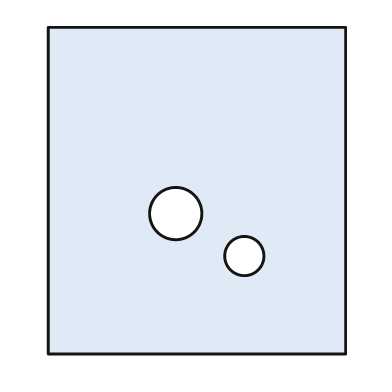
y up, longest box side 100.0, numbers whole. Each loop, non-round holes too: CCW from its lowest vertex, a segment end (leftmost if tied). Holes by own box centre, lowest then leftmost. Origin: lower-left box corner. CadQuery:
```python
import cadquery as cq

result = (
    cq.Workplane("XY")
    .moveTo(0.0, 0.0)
    .lineTo(91.0, 0.0)
    .lineTo(91.0, 100.0)
    .lineTo(0.0, 100.0)
    .close()
    .moveTo(60.0, 30.0)
    .circle(6.0)
    .moveTo(39.0, 43.0)
    .circle(8.0)
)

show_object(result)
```